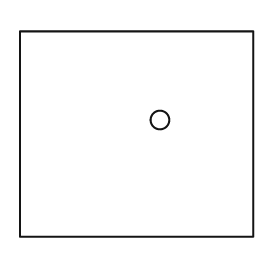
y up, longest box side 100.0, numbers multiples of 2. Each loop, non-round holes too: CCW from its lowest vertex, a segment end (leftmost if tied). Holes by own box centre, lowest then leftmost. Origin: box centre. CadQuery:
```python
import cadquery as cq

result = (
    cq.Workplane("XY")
    .moveTo(-50.0, -44.0)
    .lineTo(50.0, -44.0)
    .lineTo(50.0, 44.0)
    .lineTo(-50.0, 44.0)
    .close()
    .moveTo(10.0, 6.0)
    .circle(4.0)
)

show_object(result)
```